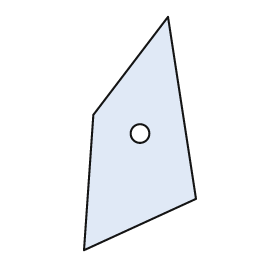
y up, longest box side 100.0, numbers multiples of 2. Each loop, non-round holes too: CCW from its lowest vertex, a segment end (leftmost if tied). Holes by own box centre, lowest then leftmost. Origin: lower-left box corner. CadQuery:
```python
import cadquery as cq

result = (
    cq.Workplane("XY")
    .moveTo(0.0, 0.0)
    .lineTo(48.0, 22.0)
    .lineTo(36.0, 100.0)
    .lineTo(4.0, 58.0)
    .close()
    .moveTo(24.0, 50.0)
    .circle(4.0)
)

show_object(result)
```